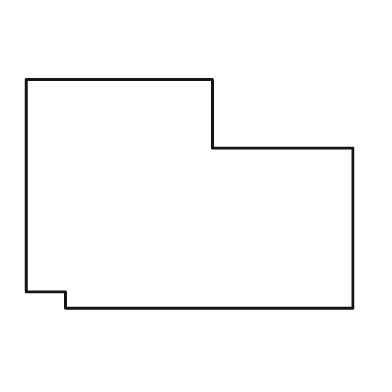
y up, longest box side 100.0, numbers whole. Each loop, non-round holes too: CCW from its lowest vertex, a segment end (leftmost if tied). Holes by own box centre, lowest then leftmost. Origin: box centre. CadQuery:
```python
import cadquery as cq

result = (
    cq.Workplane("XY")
    .moveTo(-38.0, -35.0)
    .lineTo(50.0, -35.0)
    .lineTo(50.0, 14.0)
    .lineTo(7.0, 14.0)
    .lineTo(7.0, 35.0)
    .lineTo(-50.0, 35.0)
    .lineTo(-50.0, -30.0)
    .lineTo(-38.0, -30.0)
    .close()
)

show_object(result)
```